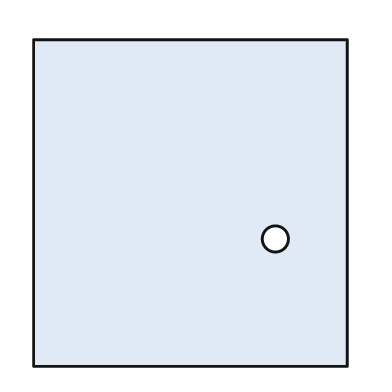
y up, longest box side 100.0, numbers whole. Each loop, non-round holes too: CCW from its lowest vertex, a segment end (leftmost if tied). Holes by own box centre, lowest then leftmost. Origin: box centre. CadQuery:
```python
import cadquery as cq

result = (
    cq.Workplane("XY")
    .moveTo(-48.0, -50.0)
    .lineTo(48.0, -50.0)
    .lineTo(48.0, 50.0)
    .lineTo(-48.0, 50.0)
    .close()
    .moveTo(26.0, -11.0)
    .circle(4.0)
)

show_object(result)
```